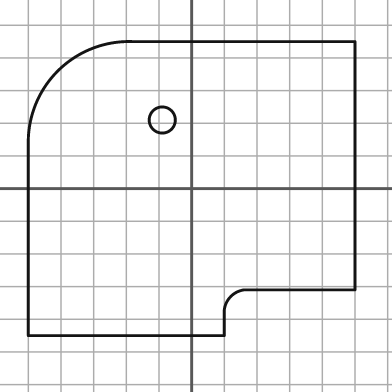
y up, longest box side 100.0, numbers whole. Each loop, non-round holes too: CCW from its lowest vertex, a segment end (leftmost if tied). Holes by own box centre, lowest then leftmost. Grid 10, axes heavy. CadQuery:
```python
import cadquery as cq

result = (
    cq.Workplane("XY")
    .moveTo(-50.0, -45.0)
    .lineTo(10.0, -45.0)
    .lineTo(10.0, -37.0)
    .threePointArc((12.0, -33.0), (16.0, -31.0))
    .lineTo(50.0, -31.0)
    .lineTo(50.0, 45.0)
    .lineTo(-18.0, 45.0)
    .threePointArc((-41.0, 36.0), (-50.0, 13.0))
    .close()
    .moveTo(-9.0, 21.0)
    .circle(4.0)
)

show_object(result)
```